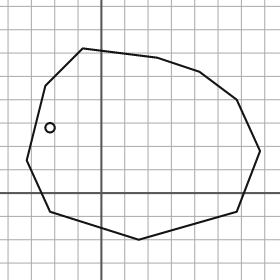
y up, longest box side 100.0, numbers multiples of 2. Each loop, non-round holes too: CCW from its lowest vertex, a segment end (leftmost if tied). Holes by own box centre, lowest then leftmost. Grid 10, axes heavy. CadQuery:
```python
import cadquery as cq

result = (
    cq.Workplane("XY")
    .moveTo(16.0, -20.0)
    .lineTo(58.0, -8.0)
    .lineTo(68.0, 18.0)
    .lineTo(58.0, 40.0)
    .lineTo(42.0, 52.0)
    .lineTo(24.0, 58.0)
    .lineTo(-8.0, 62.0)
    .lineTo(-24.0, 46.0)
    .lineTo(-32.0, 14.0)
    .lineTo(-22.0, -8.0)
    .close()
    .moveTo(-22.0, 28.0)
    .circle(2.0)
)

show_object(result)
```